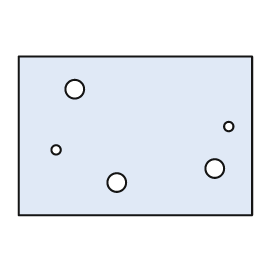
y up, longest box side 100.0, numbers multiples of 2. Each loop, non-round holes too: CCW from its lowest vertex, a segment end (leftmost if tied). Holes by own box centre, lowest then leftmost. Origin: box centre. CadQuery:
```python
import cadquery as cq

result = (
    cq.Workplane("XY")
    .moveTo(-50.0, -34.0)
    .lineTo(50.0, -34.0)
    .lineTo(50.0, 34.0)
    .lineTo(-50.0, 34.0)
    .close()
    .moveTo(-8.0, -20.0)
    .circle(4.0)
    .moveTo(34.0, -14.0)
    .circle(4.0)
    .moveTo(-34.0, -6.0)
    .circle(2.0)
    .moveTo(40.0, 4.0)
    .circle(2.0)
    .moveTo(-26.0, 20.0)
    .circle(4.0)
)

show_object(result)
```